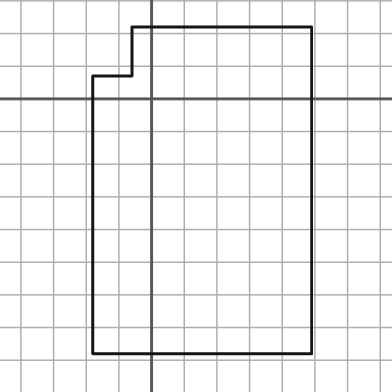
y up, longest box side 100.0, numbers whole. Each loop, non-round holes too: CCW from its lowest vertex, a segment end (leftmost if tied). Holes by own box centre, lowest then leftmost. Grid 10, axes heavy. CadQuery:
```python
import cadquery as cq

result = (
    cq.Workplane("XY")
    .moveTo(-18.0, -78.0)
    .lineTo(49.0, -78.0)
    .lineTo(49.0, 22.0)
    .lineTo(-6.0, 22.0)
    .lineTo(-6.0, 7.0)
    .lineTo(-18.0, 7.0)
    .close()
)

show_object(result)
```